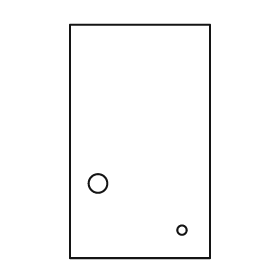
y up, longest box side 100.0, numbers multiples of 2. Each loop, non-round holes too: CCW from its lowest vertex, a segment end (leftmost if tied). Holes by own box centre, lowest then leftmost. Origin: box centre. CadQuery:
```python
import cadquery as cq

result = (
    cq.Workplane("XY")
    .moveTo(-30.0, -50.0)
    .lineTo(30.0, -50.0)
    .lineTo(30.0, 50.0)
    .lineTo(-30.0, 50.0)
    .close()
    .moveTo(18.0, -38.0)
    .circle(2.0)
    .moveTo(-18.0, -18.0)
    .circle(4.0)
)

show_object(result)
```